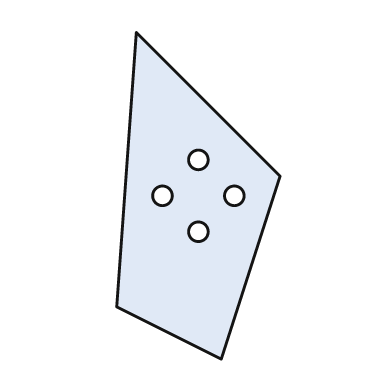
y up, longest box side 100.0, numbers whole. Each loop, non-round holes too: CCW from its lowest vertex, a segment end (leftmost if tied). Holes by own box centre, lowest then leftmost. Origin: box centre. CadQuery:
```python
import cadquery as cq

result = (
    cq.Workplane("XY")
    .moveTo(7.0, -50.0)
    .lineTo(25.0, 6.0)
    .lineTo(-19.0, 50.0)
    .lineTo(-25.0, -34.0)
    .close()
    .moveTo(0.0, -11.0)
    .circle(3.0)
    .moveTo(-11.0, 0.0)
    .circle(3.0)
    .moveTo(11.0, 0.0)
    .circle(3.0)
    .moveTo(0.0, 11.0)
    .circle(3.0)
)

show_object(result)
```